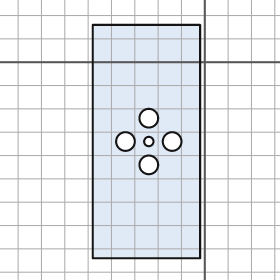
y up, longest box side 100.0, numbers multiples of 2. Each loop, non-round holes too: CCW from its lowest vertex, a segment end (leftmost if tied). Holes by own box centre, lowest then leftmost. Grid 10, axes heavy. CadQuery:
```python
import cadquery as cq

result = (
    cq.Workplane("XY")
    .moveTo(-48.0, -84.0)
    .lineTo(-2.0, -84.0)
    .lineTo(-2.0, 16.0)
    .lineTo(-48.0, 16.0)
    .close()
    .moveTo(-24.0, -44.0)
    .circle(4.0)
    .moveTo(-34.0, -34.0)
    .circle(4.0)
    .moveTo(-24.0, -34.0)
    .circle(2.0)
    .moveTo(-14.0, -34.0)
    .circle(4.0)
    .moveTo(-24.0, -24.0)
    .circle(4.0)
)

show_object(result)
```